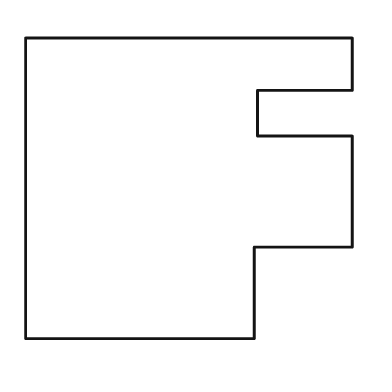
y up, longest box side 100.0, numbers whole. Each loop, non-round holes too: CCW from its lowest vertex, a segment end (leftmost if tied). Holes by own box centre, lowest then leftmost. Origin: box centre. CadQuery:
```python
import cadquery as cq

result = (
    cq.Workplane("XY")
    .moveTo(-50.0, -46.0)
    .lineTo(20.0, -46.0)
    .lineTo(20.0, -18.0)
    .lineTo(50.0, -18.0)
    .lineTo(50.0, 16.0)
    .lineTo(21.0, 16.0)
    .lineTo(21.0, 30.0)
    .lineTo(50.0, 30.0)
    .lineTo(50.0, 46.0)
    .lineTo(-50.0, 46.0)
    .close()
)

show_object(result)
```